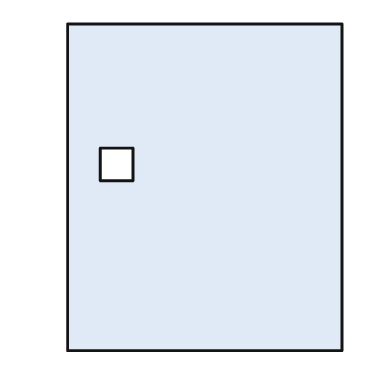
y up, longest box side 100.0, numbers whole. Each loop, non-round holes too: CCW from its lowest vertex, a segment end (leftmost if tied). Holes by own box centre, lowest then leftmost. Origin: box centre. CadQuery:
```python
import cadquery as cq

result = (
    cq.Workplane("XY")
    .moveTo(-42.0, -50.0)
    .lineTo(42.0, -50.0)
    .lineTo(42.0, 50.0)
    .lineTo(-42.0, 50.0)
    .close()
    .moveTo(-32.0, 2.0)
    .lineTo(-22.0, 2.0)
    .lineTo(-22.0, 12.0)
    .lineTo(-32.0, 12.0)
    .close()
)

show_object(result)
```